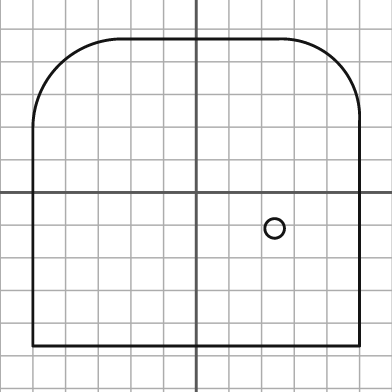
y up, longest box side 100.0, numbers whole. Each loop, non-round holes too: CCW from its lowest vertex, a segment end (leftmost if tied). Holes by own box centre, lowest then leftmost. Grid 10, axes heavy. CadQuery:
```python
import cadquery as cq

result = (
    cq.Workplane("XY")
    .moveTo(-50.0, -47.0)
    .lineTo(50.0, -47.0)
    .lineTo(50.0, 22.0)
    .threePointArc((43.0, 40.0), (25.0, 47.0))
    .lineTo(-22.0, 47.0)
    .threePointArc((-42.0, 39.0), (-50.0, 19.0))
    .close()
    .moveTo(24.0, -11.0)
    .circle(3.0)
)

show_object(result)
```